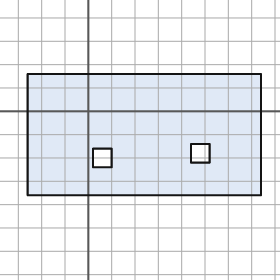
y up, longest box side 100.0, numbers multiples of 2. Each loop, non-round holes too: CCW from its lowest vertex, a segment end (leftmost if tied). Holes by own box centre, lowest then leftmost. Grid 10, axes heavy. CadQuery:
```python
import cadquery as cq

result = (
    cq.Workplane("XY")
    .moveTo(-26.0, -36.0)
    .lineTo(74.0, -36.0)
    .lineTo(74.0, 16.0)
    .lineTo(-26.0, 16.0)
    .close()
    .moveTo(2.0, -24.0)
    .lineTo(10.0, -24.0)
    .lineTo(10.0, -16.0)
    .lineTo(2.0, -16.0)
    .close()
    .moveTo(44.0, -22.0)
    .lineTo(52.0, -22.0)
    .lineTo(52.0, -14.0)
    .lineTo(44.0, -14.0)
    .close()
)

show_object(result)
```